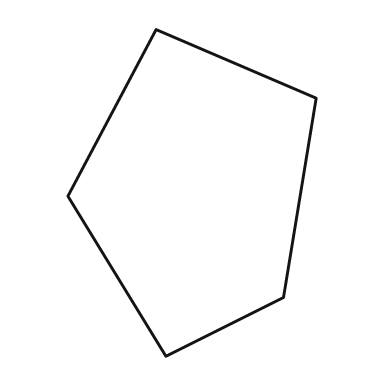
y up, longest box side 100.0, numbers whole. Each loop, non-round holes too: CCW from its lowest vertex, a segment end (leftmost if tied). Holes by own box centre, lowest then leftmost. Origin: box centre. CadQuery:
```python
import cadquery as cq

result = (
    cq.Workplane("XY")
    .moveTo(-8.0, -50.0)
    .lineTo(28.0, -32.0)
    .lineTo(38.0, 29.0)
    .lineTo(-11.0, 50.0)
    .lineTo(-38.0, -1.0)
    .close()
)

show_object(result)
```